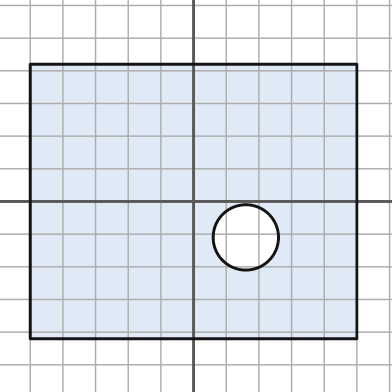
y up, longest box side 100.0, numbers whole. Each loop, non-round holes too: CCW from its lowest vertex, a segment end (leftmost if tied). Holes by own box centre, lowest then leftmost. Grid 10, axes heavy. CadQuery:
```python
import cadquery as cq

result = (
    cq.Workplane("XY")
    .moveTo(-50.0, -42.0)
    .lineTo(50.0, -42.0)
    .lineTo(50.0, 42.0)
    .lineTo(-50.0, 42.0)
    .close()
    .moveTo(16.0, -11.0)
    .circle(10.0)
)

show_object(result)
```